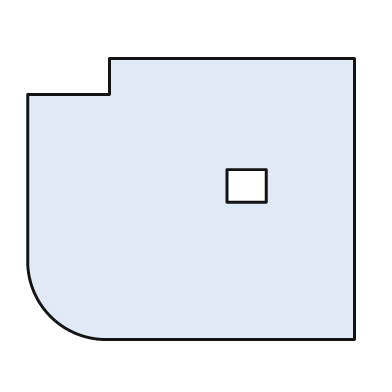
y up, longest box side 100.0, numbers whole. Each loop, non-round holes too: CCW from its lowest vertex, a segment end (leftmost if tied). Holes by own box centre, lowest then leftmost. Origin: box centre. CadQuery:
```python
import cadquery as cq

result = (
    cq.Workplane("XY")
    .moveTo(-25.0, -43.0)
    .lineTo(50.0, -43.0)
    .lineTo(50.0, 43.0)
    .lineTo(-25.0, 43.0)
    .lineTo(-25.0, 32.0)
    .lineTo(-50.0, 32.0)
    .lineTo(-50.0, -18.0)
    .threePointArc((-43.0, -36.0), (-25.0, -43.0))
    .close()
    .moveTo(11.0, -1.0)
    .lineTo(23.0, -1.0)
    .lineTo(23.0, 9.0)
    .lineTo(11.0, 9.0)
    .close()
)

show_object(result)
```